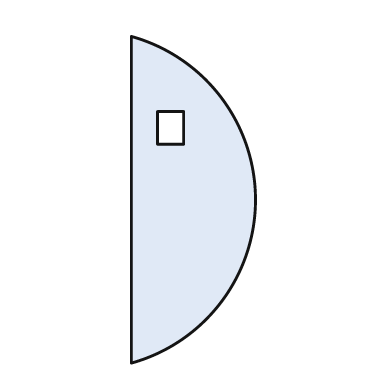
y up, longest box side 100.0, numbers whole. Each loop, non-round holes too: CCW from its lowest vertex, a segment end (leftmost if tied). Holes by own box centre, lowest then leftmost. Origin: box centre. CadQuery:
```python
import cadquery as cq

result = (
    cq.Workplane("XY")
    .moveTo(-19.0, -50.0)
    .threePointArc((19.0, 0.0), (-19.0, 50.0))
    .close()
    .moveTo(-11.0, 17.0)
    .lineTo(-3.0, 17.0)
    .lineTo(-3.0, 27.0)
    .lineTo(-11.0, 27.0)
    .close()
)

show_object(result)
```